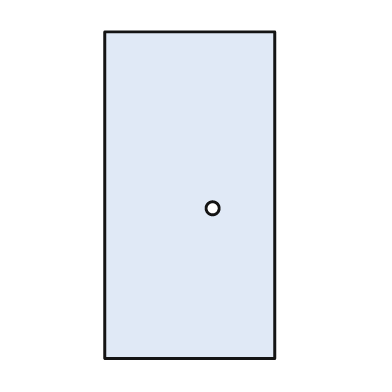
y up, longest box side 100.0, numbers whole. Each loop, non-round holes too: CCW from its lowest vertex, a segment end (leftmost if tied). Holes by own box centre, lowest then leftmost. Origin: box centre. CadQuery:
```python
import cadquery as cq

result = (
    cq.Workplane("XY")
    .moveTo(-26.0, -50.0)
    .lineTo(26.0, -50.0)
    .lineTo(26.0, 50.0)
    .lineTo(-26.0, 50.0)
    .close()
    .moveTo(7.0, -4.0)
    .circle(2.0)
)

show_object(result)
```